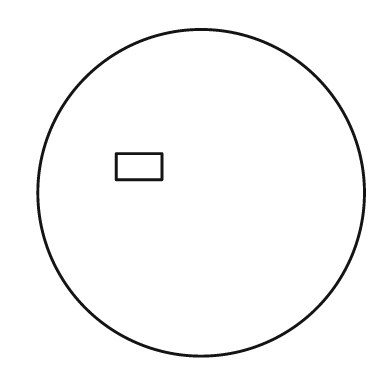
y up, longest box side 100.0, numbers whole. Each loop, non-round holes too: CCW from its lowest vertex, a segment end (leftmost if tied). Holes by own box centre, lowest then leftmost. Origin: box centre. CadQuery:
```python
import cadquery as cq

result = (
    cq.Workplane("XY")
    .moveTo(0.0, 0.0)
    .circle(50.0)
    .moveTo(-26.0, 4.0)
    .lineTo(-12.0, 4.0)
    .lineTo(-12.0, 12.0)
    .lineTo(-26.0, 12.0)
    .close()
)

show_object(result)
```